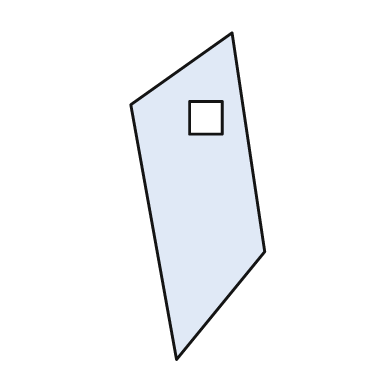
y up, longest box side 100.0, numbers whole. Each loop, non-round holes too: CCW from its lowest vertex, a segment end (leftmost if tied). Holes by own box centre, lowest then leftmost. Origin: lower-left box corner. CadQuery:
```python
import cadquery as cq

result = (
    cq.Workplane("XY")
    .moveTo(14.0, 0.0)
    .lineTo(41.0, 33.0)
    .lineTo(31.0, 100.0)
    .lineTo(0.0, 78.0)
    .close()
    .moveTo(18.0, 69.0)
    .lineTo(28.0, 69.0)
    .lineTo(28.0, 79.0)
    .lineTo(18.0, 79.0)
    .close()
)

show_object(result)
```